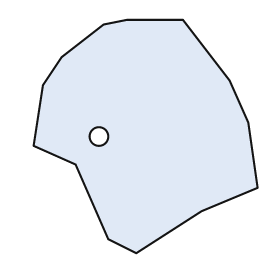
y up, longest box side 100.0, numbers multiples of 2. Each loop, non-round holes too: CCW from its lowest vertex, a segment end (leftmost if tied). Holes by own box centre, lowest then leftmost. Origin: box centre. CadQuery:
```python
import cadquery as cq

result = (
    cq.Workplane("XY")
    .moveTo(-4.0, -50.0)
    .lineTo(24.0, -32.0)
    .lineTo(48.0, -22.0)
    .lineTo(44.0, 6.0)
    .lineTo(36.0, 24.0)
    .lineTo(16.0, 50.0)
    .lineTo(-8.0, 50.0)
    .lineTo(-18.0, 48.0)
    .lineTo(-36.0, 34.0)
    .lineTo(-44.0, 22.0)
    .lineTo(-48.0, -4.0)
    .lineTo(-30.0, -12.0)
    .lineTo(-16.0, -44.0)
    .close()
    .moveTo(-20.0, 0.0)
    .circle(4.0)
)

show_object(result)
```